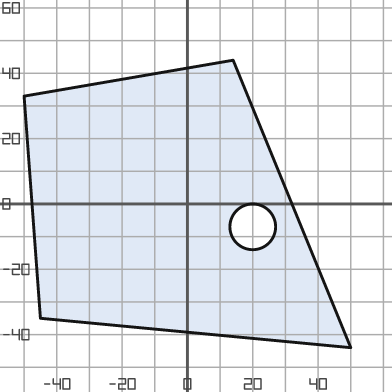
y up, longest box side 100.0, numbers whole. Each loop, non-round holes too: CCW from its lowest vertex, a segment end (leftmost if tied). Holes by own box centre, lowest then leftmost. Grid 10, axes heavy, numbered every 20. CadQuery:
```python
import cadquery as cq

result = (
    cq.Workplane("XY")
    .moveTo(50.0, -44.0)
    .lineTo(14.0, 44.0)
    .lineTo(-50.0, 33.0)
    .lineTo(-45.0, -35.0)
    .close()
    .moveTo(20.0, -7.0)
    .circle(7.0)
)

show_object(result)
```